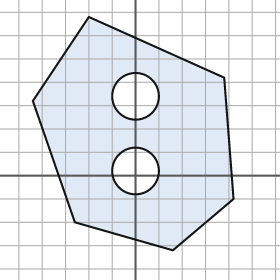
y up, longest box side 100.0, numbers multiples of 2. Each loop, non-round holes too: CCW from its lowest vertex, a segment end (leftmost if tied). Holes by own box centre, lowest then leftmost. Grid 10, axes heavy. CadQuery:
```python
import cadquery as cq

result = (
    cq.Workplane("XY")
    .moveTo(16.0, -32.0)
    .lineTo(42.0, -10.0)
    .lineTo(38.0, 42.0)
    .lineTo(-20.0, 68.0)
    .lineTo(-44.0, 32.0)
    .lineTo(-26.0, -20.0)
    .close()
    .moveTo(0.0, 2.0)
    .circle(10.0)
    .moveTo(0.0, 34.0)
    .circle(10.0)
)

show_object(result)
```